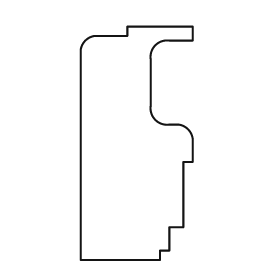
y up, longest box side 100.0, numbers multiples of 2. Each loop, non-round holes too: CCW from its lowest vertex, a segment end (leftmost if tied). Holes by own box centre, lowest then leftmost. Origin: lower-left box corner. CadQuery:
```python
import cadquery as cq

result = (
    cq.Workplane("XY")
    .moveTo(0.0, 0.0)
    .lineTo(34.0, 0.0)
    .lineTo(34.0, 4.0)
    .lineTo(38.0, 4.0)
    .lineTo(38.0, 14.0)
    .lineTo(44.0, 14.0)
    .lineTo(44.0, 42.0)
    .lineTo(48.0, 42.0)
    .lineTo(48.0, 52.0)
    .threePointArc((46.0, 56.0), (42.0, 58.0))
    .lineTo(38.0, 58.0)
    .threePointArc((32.0, 60.0), (30.0, 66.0))
    .lineTo(30.0, 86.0)
    .threePointArc((32.0, 92.0), (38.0, 94.0))
    .lineTo(48.0, 94.0)
    .lineTo(48.0, 100.0)
    .lineTo(20.0, 100.0)
    .lineTo(20.0, 96.0)
    .lineTo(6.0, 96.0)
    .threePointArc((2.0, 94.0), (0.0, 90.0))
    .close()
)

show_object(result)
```